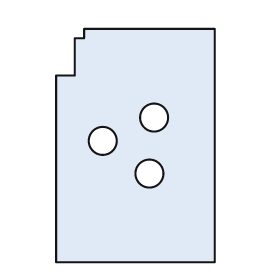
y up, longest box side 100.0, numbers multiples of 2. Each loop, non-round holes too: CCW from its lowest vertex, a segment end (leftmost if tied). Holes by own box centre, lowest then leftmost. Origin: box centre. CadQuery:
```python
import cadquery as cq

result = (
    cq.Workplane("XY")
    .moveTo(-34.0, -50.0)
    .lineTo(34.0, -50.0)
    .lineTo(34.0, 50.0)
    .lineTo(-22.0, 50.0)
    .lineTo(-22.0, 46.0)
    .lineTo(-26.0, 46.0)
    .lineTo(-26.0, 30.0)
    .lineTo(-34.0, 30.0)
    .close()
    .moveTo(6.0, -12.0)
    .circle(6.0)
    .moveTo(-14.0, 2.0)
    .circle(6.0)
    .moveTo(8.0, 12.0)
    .circle(6.0)
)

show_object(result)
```